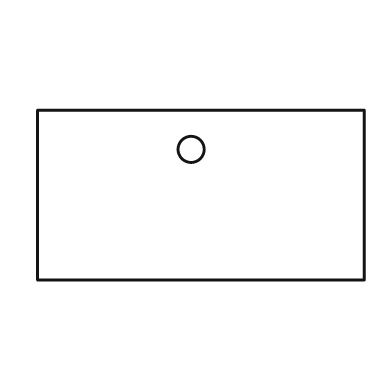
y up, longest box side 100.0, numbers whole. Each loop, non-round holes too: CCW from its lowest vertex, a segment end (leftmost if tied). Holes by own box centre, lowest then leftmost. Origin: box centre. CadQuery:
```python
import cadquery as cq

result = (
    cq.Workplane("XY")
    .moveTo(-50.0, -26.0)
    .lineTo(50.0, -26.0)
    .lineTo(50.0, 26.0)
    .lineTo(-50.0, 26.0)
    .close()
    .moveTo(-3.0, 14.0)
    .circle(4.0)
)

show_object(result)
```